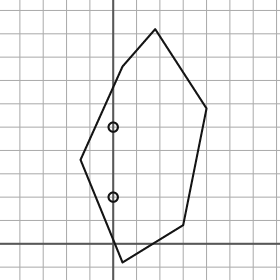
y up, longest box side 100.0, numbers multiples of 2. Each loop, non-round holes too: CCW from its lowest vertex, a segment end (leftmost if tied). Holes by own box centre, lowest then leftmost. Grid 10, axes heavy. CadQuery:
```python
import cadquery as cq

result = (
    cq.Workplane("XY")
    .moveTo(4.0, -8.0)
    .lineTo(30.0, 8.0)
    .lineTo(40.0, 58.0)
    .lineTo(18.0, 92.0)
    .lineTo(4.0, 76.0)
    .lineTo(-14.0, 36.0)
    .close()
    .moveTo(0.0, 20.0)
    .circle(2.0)
    .moveTo(0.0, 50.0)
    .circle(2.0)
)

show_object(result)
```